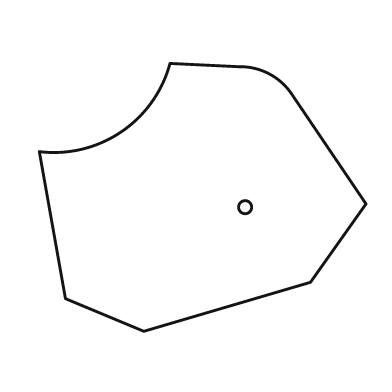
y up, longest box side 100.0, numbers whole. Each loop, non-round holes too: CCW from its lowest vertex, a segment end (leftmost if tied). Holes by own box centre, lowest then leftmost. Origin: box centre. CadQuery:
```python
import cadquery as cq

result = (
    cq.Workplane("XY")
    .moveTo(-18.0, -41.0)
    .lineTo(33.0, -26.0)
    .lineTo(50.0, -2.0)
    .lineTo(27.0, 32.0)
    .threePointArc((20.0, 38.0), (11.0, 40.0))
    .lineTo(-10.0, 41.0)
    .threePointArc((-25.0, 20.0), (-50.0, 14.0))
    .lineTo(-42.0, -31.0)
    .close()
    .moveTo(13.0, -3.0)
    .circle(2.0)
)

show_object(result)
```